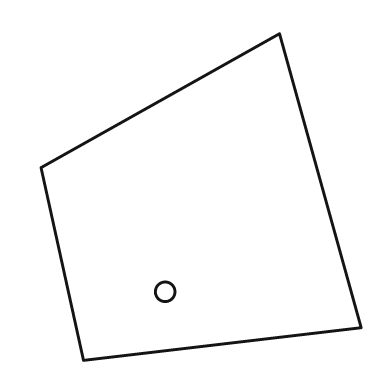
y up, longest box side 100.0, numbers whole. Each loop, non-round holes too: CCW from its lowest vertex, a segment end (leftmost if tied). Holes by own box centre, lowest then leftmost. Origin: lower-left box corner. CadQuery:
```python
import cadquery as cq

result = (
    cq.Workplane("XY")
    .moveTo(13.0, 0.0)
    .lineTo(98.0, 10.0)
    .lineTo(73.0, 100.0)
    .lineTo(0.0, 59.0)
    .close()
    .moveTo(38.0, 21.0)
    .circle(3.0)
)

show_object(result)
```